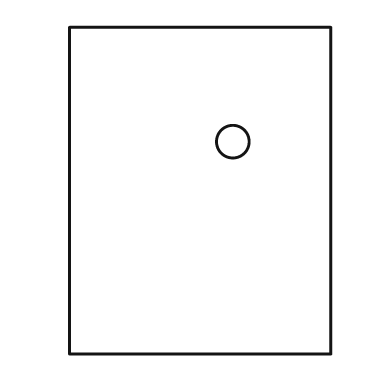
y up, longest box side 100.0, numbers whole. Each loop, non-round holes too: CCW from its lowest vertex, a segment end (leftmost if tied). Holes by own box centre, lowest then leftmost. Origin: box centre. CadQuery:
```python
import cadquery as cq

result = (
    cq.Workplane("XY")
    .moveTo(-40.0, -50.0)
    .lineTo(40.0, -50.0)
    .lineTo(40.0, 50.0)
    .lineTo(-40.0, 50.0)
    .close()
    .moveTo(10.0, 15.0)
    .circle(5.0)
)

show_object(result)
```